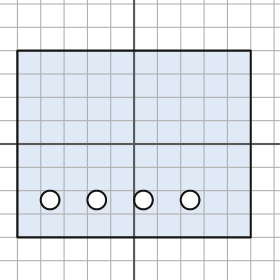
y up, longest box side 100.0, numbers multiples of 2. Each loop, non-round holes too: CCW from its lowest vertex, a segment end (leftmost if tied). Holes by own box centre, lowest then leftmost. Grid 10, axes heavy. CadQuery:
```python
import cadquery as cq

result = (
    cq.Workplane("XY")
    .moveTo(-50.0, -40.0)
    .lineTo(50.0, -40.0)
    .lineTo(50.0, 40.0)
    .lineTo(-50.0, 40.0)
    .close()
    .moveTo(-36.0, -24.0)
    .circle(4.0)
    .moveTo(-16.0, -24.0)
    .circle(4.0)
    .moveTo(4.0, -24.0)
    .circle(4.0)
    .moveTo(24.0, -24.0)
    .circle(4.0)
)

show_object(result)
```